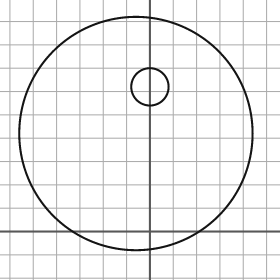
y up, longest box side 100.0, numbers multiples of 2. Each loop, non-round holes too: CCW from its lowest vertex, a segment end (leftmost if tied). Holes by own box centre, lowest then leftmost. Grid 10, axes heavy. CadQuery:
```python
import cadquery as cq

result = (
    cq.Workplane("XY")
    .moveTo(-6.0, 42.0)
    .circle(50.0)
    .moveTo(0.0, 62.0)
    .circle(8.0)
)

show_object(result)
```